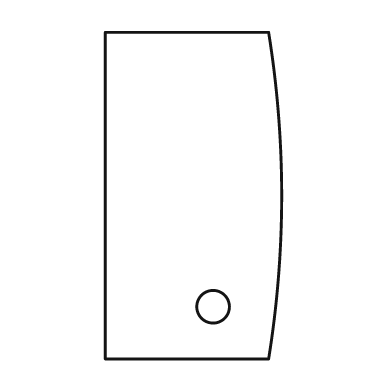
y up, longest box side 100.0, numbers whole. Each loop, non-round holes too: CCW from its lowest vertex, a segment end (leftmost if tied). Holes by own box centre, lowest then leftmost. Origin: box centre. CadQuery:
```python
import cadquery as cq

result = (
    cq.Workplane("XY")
    .moveTo(-27.0, -50.0)
    .lineTo(23.0, -50.0)
    .threePointArc((27.0, 0.0), (23.0, 50.0))
    .lineTo(-27.0, 50.0)
    .close()
    .moveTo(6.0, -34.0)
    .circle(5.0)
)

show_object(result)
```